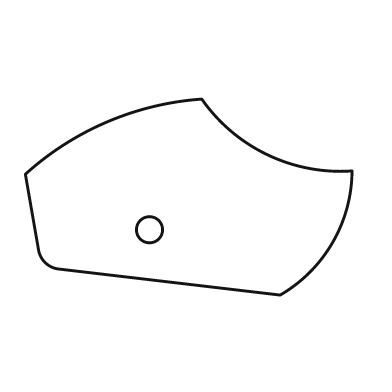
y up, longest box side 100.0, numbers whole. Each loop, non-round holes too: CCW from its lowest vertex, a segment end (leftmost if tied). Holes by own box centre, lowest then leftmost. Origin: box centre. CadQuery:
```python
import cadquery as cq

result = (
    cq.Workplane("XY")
    .moveTo(28.0, -30.0)
    .threePointArc((44.0, -14.0), (50.0, 8.0))
    .threePointArc((24.0, 13.0), (4.0, 30.0))
    .threePointArc((-25.0, 23.0), (-50.0, 7.0))
    .lineTo(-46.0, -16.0)
    .threePointArc((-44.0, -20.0), (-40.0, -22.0))
    .close()
    .moveTo(-12.0, -10.0)
    .circle(4.0)
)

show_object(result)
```